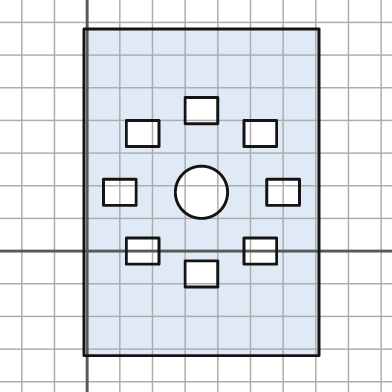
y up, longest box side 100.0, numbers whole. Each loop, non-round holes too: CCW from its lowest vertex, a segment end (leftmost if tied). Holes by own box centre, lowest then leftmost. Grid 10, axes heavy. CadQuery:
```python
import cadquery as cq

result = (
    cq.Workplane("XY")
    .moveTo(-1.0, -32.0)
    .lineTo(71.0, -32.0)
    .lineTo(71.0, 68.0)
    .lineTo(-1.0, 68.0)
    .close()
    .moveTo(30.0, -11.0)
    .lineTo(40.0, -11.0)
    .lineTo(40.0, -3.0)
    .lineTo(30.0, -3.0)
    .close()
    .moveTo(12.0, -4.0)
    .lineTo(22.0, -4.0)
    .lineTo(22.0, 4.0)
    .lineTo(12.0, 4.0)
    .close()
    .moveTo(48.0, -4.0)
    .lineTo(58.0, -4.0)
    .lineTo(58.0, 4.0)
    .lineTo(48.0, 4.0)
    .close()
    .moveTo(5.0, 14.0)
    .lineTo(15.0, 14.0)
    .lineTo(15.0, 22.0)
    .lineTo(5.0, 22.0)
    .close()
    .moveTo(35.0, 18.0)
    .circle(8.0)
    .moveTo(55.0, 14.0)
    .lineTo(65.0, 14.0)
    .lineTo(65.0, 22.0)
    .lineTo(55.0, 22.0)
    .close()
    .moveTo(12.0, 32.0)
    .lineTo(22.0, 32.0)
    .lineTo(22.0, 40.0)
    .lineTo(12.0, 40.0)
    .close()
    .moveTo(48.0, 32.0)
    .lineTo(58.0, 32.0)
    .lineTo(58.0, 40.0)
    .lineTo(48.0, 40.0)
    .close()
    .moveTo(30.0, 39.0)
    .lineTo(40.0, 39.0)
    .lineTo(40.0, 47.0)
    .lineTo(30.0, 47.0)
    .close()
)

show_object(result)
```